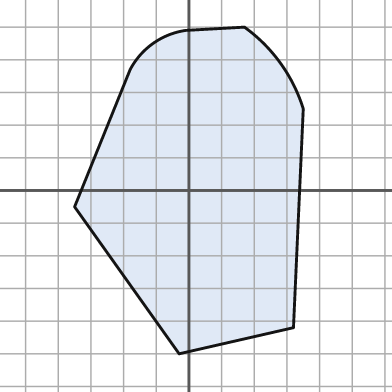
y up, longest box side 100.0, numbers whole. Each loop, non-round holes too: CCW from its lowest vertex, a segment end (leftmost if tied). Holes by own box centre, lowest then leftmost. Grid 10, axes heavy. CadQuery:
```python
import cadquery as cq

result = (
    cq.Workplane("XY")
    .moveTo(-3.0, -50.0)
    .lineTo(32.0, -42.0)
    .lineTo(35.0, 25.0)
    .threePointArc((28.0, 39.0), (17.0, 50.0))
    .lineTo(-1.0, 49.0)
    .threePointArc((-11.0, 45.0), (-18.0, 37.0))
    .lineTo(-35.0, -5.0)
    .close()
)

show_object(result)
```